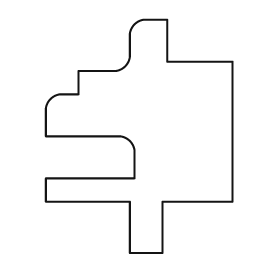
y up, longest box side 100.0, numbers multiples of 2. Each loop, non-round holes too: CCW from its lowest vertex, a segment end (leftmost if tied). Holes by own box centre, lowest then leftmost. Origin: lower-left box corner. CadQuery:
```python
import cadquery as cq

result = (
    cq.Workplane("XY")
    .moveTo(36.0, 0.0)
    .lineTo(50.0, 0.0)
    .lineTo(50.0, 22.0)
    .lineTo(80.0, 22.0)
    .lineTo(80.0, 82.0)
    .lineTo(52.0, 82.0)
    .lineTo(52.0, 100.0)
    .lineTo(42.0, 100.0)
    .threePointArc((38.0, 98.0), (36.0, 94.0))
    .lineTo(36.0, 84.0)
    .threePointArc((34.0, 80.0), (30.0, 78.0))
    .lineTo(14.0, 78.0)
    .lineTo(14.0, 68.0)
    .lineTo(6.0, 68.0)
    .threePointArc((2.0, 66.0), (0.0, 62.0))
    .lineTo(0.0, 50.0)
    .lineTo(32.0, 50.0)
    .threePointArc((36.0, 48.0), (38.0, 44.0))
    .lineTo(38.0, 32.0)
    .lineTo(0.0, 32.0)
    .lineTo(0.0, 22.0)
    .lineTo(36.0, 22.0)
    .close()
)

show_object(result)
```